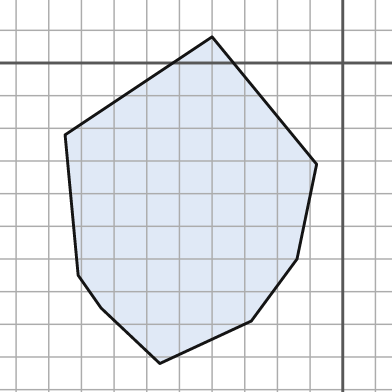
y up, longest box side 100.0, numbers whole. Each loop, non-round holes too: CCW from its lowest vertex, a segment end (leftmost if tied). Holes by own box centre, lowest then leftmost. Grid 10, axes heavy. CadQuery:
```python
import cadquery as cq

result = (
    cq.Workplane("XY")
    .moveTo(-56.0, -92.0)
    .lineTo(-28.0, -79.0)
    .lineTo(-14.0, -60.0)
    .lineTo(-8.0, -31.0)
    .lineTo(-40.0, 8.0)
    .lineTo(-85.0, -22.0)
    .lineTo(-81.0, -65.0)
    .lineTo(-74.0, -75.0)
    .close()
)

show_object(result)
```